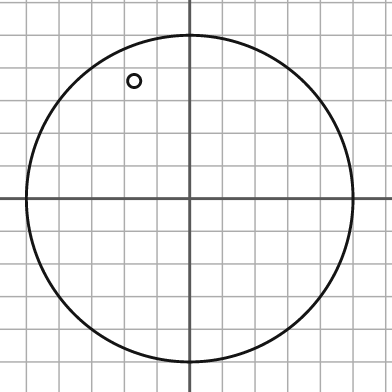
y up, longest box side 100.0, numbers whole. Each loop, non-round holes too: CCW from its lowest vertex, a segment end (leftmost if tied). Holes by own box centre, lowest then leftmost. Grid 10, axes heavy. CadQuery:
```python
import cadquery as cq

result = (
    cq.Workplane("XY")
    .moveTo(0.0, 0.0)
    .circle(50.0)
    .moveTo(-17.0, 36.0)
    .circle(2.0)
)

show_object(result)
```